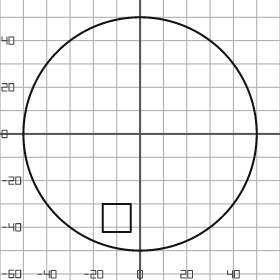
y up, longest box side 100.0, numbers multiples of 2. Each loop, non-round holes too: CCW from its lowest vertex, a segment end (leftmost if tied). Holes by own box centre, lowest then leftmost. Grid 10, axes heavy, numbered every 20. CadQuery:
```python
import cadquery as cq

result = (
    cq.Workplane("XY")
    .moveTo(0.0, 0.0)
    .circle(50.0)
    .moveTo(-16.0, -42.0)
    .lineTo(-4.0, -42.0)
    .lineTo(-4.0, -30.0)
    .lineTo(-16.0, -30.0)
    .close()
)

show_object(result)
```